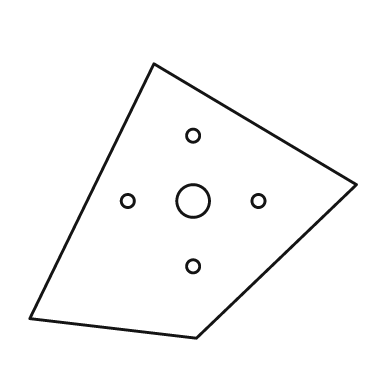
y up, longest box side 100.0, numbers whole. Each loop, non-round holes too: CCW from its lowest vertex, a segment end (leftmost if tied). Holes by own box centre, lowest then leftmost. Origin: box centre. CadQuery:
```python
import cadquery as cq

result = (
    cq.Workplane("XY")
    .moveTo(1.0, -42.0)
    .lineTo(50.0, 5.0)
    .lineTo(-12.0, 42.0)
    .lineTo(-50.0, -36.0)
    .close()
    .moveTo(0.0, -20.0)
    .circle(2.0)
    .moveTo(-20.0, 0.0)
    .circle(2.0)
    .moveTo(0.0, 0.0)
    .circle(5.0)
    .moveTo(20.0, 0.0)
    .circle(2.0)
    .moveTo(0.0, 20.0)
    .circle(2.0)
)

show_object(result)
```